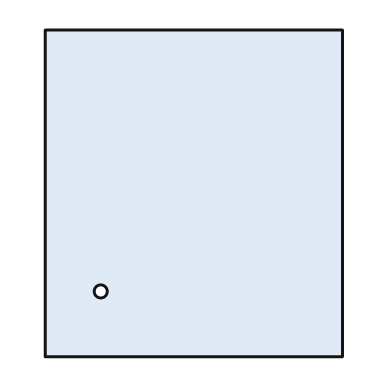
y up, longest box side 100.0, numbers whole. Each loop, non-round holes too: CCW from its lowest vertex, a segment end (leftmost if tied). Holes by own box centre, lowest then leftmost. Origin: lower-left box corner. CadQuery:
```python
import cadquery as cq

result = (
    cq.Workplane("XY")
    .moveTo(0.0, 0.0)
    .lineTo(91.0, 0.0)
    .lineTo(91.0, 100.0)
    .lineTo(0.0, 100.0)
    .close()
    .moveTo(17.0, 20.0)
    .circle(2.0)
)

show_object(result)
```